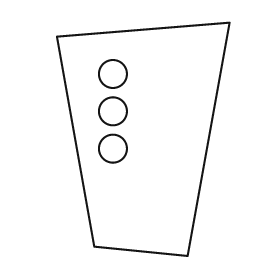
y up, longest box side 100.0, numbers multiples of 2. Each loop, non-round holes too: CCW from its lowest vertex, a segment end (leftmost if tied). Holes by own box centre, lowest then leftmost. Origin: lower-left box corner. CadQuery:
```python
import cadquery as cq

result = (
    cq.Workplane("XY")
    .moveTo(56.0, 0.0)
    .lineTo(74.0, 100.0)
    .lineTo(0.0, 94.0)
    .lineTo(16.0, 4.0)
    .close()
    .moveTo(24.0, 46.0)
    .circle(6.0)
    .moveTo(24.0, 62.0)
    .circle(6.0)
    .moveTo(24.0, 78.0)
    .circle(6.0)
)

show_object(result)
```